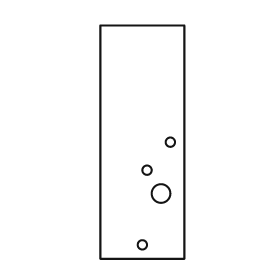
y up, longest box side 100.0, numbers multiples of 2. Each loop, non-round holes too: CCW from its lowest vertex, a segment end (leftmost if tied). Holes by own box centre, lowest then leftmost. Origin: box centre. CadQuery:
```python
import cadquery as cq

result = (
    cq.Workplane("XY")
    .moveTo(-18.0, -50.0)
    .lineTo(18.0, -50.0)
    .lineTo(18.0, 50.0)
    .lineTo(-18.0, 50.0)
    .close()
    .moveTo(0.0, -44.0)
    .circle(2.0)
    .moveTo(8.0, -22.0)
    .circle(4.0)
    .moveTo(2.0, -12.0)
    .circle(2.0)
    .moveTo(12.0, 0.0)
    .circle(2.0)
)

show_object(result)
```